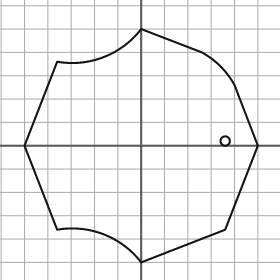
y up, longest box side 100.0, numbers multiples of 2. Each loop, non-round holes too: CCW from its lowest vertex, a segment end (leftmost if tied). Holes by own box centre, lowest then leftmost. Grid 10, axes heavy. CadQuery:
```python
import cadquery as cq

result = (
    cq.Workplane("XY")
    .moveTo(0.0, -50.0)
    .lineTo(36.0, -36.0)
    .lineTo(50.0, 0.0)
    .lineTo(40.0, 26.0)
    .threePointArc((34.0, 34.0), (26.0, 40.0))
    .lineTo(0.0, 50.0)
    .threePointArc((-16.0, 38.0), (-36.0, 36.0))
    .lineTo(-50.0, 0.0)
    .lineTo(-36.0, -36.0)
    .threePointArc((-16.0, -38.0), (0.0, -50.0))
    .close()
    .moveTo(36.0, 2.0)
    .circle(2.0)
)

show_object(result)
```